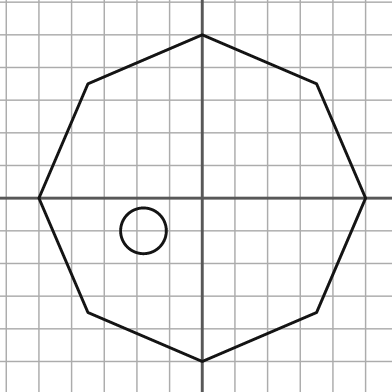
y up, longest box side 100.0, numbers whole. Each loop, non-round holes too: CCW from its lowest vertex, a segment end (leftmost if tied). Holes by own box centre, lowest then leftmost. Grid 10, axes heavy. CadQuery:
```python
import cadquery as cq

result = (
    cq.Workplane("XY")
    .moveTo(0.0, -50.0)
    .lineTo(35.0, -35.0)
    .lineTo(50.0, 0.0)
    .lineTo(35.0, 35.0)
    .lineTo(0.0, 50.0)
    .lineTo(-35.0, 35.0)
    .lineTo(-50.0, 0.0)
    .lineTo(-35.0, -35.0)
    .close()
    .moveTo(-18.0, -10.0)
    .circle(7.0)
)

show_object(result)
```